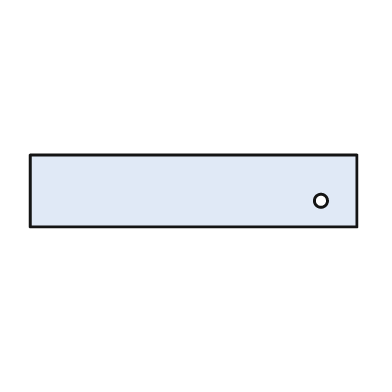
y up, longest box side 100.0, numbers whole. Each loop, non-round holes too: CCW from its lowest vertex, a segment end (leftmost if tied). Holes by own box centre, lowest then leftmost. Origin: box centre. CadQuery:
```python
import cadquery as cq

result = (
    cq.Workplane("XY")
    .moveTo(-50.0, -11.0)
    .lineTo(50.0, -11.0)
    .lineTo(50.0, 11.0)
    .lineTo(-50.0, 11.0)
    .close()
    .moveTo(39.0, -3.0)
    .circle(2.0)
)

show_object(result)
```